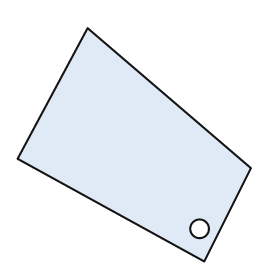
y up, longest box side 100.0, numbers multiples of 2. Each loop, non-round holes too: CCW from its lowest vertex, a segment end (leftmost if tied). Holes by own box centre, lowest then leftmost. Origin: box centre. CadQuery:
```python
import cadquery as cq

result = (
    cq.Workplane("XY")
    .moveTo(30.0, -50.0)
    .lineTo(50.0, -10.0)
    .lineTo(-20.0, 50.0)
    .lineTo(-50.0, -6.0)
    .close()
    .moveTo(28.0, -36.0)
    .circle(4.0)
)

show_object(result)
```